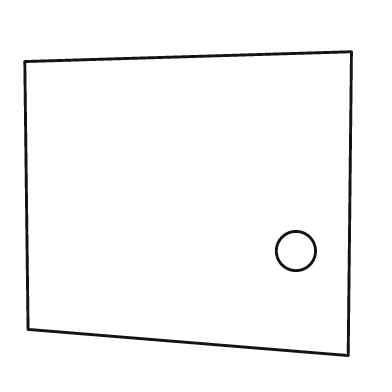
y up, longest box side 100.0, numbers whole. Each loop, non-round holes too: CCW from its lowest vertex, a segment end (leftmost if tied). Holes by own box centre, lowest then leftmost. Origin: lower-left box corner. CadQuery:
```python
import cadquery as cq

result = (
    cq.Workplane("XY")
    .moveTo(99.0, 0.0)
    .lineTo(100.0, 93.0)
    .lineTo(0.0, 90.0)
    .lineTo(1.0, 8.0)
    .close()
    .moveTo(83.0, 32.0)
    .circle(6.0)
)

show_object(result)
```